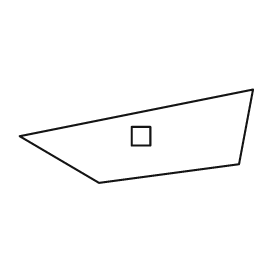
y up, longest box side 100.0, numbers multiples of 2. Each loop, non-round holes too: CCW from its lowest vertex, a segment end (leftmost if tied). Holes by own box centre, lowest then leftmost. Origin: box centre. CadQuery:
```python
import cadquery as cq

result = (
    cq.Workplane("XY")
    .moveTo(-16.0, -20.0)
    .lineTo(44.0, -12.0)
    .lineTo(50.0, 20.0)
    .lineTo(-50.0, 0.0)
    .close()
    .moveTo(-2.0, -4.0)
    .lineTo(6.0, -4.0)
    .lineTo(6.0, 4.0)
    .lineTo(-2.0, 4.0)
    .close()
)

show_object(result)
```